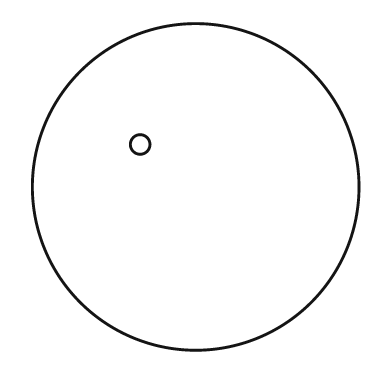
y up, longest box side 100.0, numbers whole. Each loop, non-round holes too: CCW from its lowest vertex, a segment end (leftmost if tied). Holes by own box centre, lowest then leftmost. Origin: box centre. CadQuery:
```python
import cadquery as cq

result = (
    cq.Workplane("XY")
    .moveTo(0.0, 0.0)
    .circle(50.0)
    .moveTo(-17.0, 13.0)
    .circle(3.0)
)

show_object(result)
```